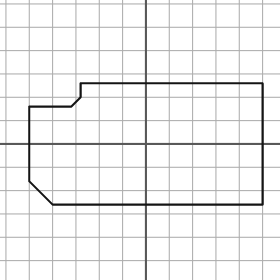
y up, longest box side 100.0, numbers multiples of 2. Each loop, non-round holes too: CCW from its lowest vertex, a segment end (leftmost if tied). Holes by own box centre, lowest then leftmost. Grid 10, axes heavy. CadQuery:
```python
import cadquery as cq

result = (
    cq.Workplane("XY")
    .moveTo(-40.0, -26.0)
    .lineTo(50.0, -26.0)
    .lineTo(50.0, 26.0)
    .lineTo(-28.0, 26.0)
    .lineTo(-28.0, 20.0)
    .lineTo(-32.0, 16.0)
    .lineTo(-50.0, 16.0)
    .lineTo(-50.0, -16.0)
    .close()
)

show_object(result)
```